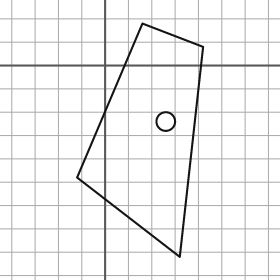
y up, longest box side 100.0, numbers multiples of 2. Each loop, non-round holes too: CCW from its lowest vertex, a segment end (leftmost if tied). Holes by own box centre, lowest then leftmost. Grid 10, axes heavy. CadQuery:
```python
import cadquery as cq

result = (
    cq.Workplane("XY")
    .moveTo(32.0, -82.0)
    .lineTo(42.0, 8.0)
    .lineTo(16.0, 18.0)
    .lineTo(-12.0, -48.0)
    .close()
    .moveTo(26.0, -24.0)
    .circle(4.0)
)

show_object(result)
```